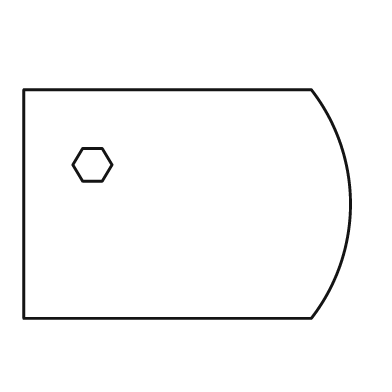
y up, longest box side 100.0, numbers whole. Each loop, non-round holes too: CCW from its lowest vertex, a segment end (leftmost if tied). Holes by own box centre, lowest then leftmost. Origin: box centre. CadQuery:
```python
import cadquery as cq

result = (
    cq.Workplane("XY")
    .moveTo(-50.0, -35.0)
    .lineTo(38.0, -35.0)
    .threePointArc((50.0, 0.0), (38.0, 35.0))
    .lineTo(-50.0, 35.0)
    .close()
    .moveTo(-32.0, 7.0)
    .lineTo(-26.0, 7.0)
    .lineTo(-23.0, 12.0)
    .lineTo(-26.0, 17.0)
    .lineTo(-32.0, 17.0)
    .lineTo(-35.0, 12.0)
    .close()
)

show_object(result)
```